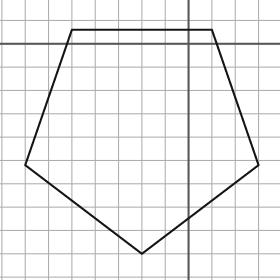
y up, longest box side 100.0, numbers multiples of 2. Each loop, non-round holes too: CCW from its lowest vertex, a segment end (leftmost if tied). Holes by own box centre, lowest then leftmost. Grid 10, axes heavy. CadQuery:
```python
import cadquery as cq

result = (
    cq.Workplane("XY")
    .moveTo(-20.0, -90.0)
    .lineTo(30.0, -52.0)
    .lineTo(10.0, 6.0)
    .lineTo(-50.0, 6.0)
    .lineTo(-70.0, -52.0)
    .close()
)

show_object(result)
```